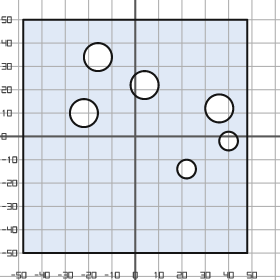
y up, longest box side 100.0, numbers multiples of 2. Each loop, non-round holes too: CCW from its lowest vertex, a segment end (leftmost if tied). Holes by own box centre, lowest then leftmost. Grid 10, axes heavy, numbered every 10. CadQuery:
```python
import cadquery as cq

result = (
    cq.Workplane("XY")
    .moveTo(-48.0, -50.0)
    .lineTo(48.0, -50.0)
    .lineTo(48.0, 50.0)
    .lineTo(-48.0, 50.0)
    .close()
    .moveTo(22.0, -14.0)
    .circle(4.0)
    .moveTo(40.0, -2.0)
    .circle(4.0)
    .moveTo(-22.0, 10.0)
    .circle(6.0)
    .moveTo(36.0, 12.0)
    .circle(6.0)
    .moveTo(4.0, 22.0)
    .circle(6.0)
    .moveTo(-16.0, 34.0)
    .circle(6.0)
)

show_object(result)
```